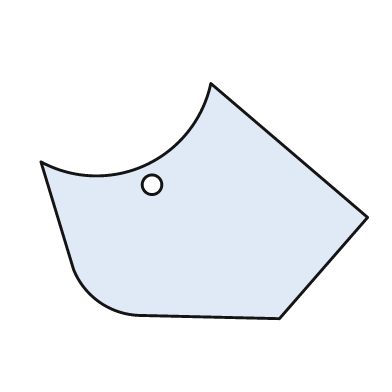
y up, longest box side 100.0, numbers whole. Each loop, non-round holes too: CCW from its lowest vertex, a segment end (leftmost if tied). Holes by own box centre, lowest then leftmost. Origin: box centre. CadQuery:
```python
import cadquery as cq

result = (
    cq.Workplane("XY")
    .moveTo(23.0, -36.0)
    .lineTo(50.0, -5.0)
    .lineTo(2.0, 36.0)
    .threePointArc((-18.0, 11.0), (-50.0, 12.0))
    .lineTo(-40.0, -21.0)
    .threePointArc((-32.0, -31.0), (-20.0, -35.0))
    .close()
    .moveTo(-16.0, 5.0)
    .circle(3.0)
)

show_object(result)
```